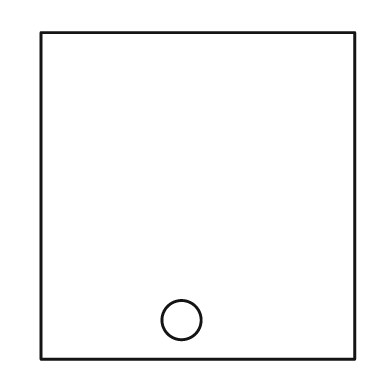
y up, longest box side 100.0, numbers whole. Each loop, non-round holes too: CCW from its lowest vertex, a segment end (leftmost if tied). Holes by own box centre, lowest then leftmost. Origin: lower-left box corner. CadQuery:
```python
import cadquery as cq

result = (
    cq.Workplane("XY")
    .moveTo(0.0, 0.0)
    .lineTo(96.0, 0.0)
    .lineTo(96.0, 100.0)
    .lineTo(0.0, 100.0)
    .close()
    .moveTo(43.0, 12.0)
    .circle(6.0)
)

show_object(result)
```